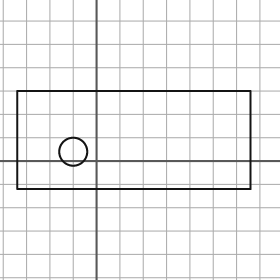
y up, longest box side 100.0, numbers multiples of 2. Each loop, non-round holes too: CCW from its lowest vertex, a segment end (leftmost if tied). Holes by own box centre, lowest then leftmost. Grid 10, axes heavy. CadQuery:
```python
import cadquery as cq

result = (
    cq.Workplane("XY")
    .moveTo(-34.0, -12.0)
    .lineTo(66.0, -12.0)
    .lineTo(66.0, 30.0)
    .lineTo(-34.0, 30.0)
    .close()
    .moveTo(-10.0, 4.0)
    .circle(6.0)
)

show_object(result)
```